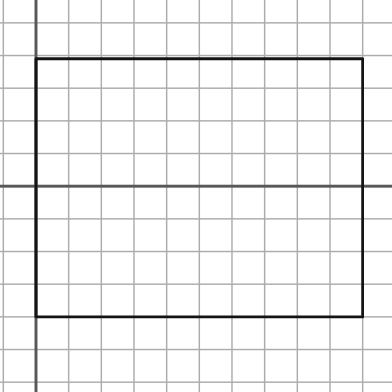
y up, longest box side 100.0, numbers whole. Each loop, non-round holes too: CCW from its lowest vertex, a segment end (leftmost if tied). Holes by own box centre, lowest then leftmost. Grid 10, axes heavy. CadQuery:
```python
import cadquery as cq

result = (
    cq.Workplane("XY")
    .moveTo(0.0, -40.0)
    .lineTo(100.0, -40.0)
    .lineTo(100.0, 39.0)
    .lineTo(0.0, 39.0)
    .close()
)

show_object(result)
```